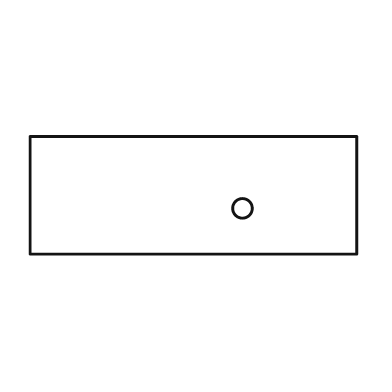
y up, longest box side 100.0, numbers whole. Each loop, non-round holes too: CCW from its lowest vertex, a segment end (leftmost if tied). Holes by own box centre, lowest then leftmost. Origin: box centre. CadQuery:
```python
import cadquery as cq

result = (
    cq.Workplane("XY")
    .moveTo(-50.0, -18.0)
    .lineTo(50.0, -18.0)
    .lineTo(50.0, 18.0)
    .lineTo(-50.0, 18.0)
    .close()
    .moveTo(15.0, -4.0)
    .circle(3.0)
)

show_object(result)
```